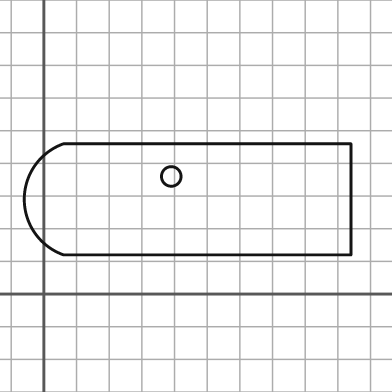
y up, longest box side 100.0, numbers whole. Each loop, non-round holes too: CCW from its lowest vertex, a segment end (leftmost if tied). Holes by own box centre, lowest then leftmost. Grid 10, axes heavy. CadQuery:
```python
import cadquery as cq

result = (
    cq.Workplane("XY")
    .moveTo(6.0, 12.0)
    .lineTo(94.0, 12.0)
    .lineTo(94.0, 46.0)
    .lineTo(6.0, 46.0)
    .threePointArc((-6.0, 29.0), (6.0, 12.0))
    .close()
    .moveTo(39.0, 36.0)
    .circle(3.0)
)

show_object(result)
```